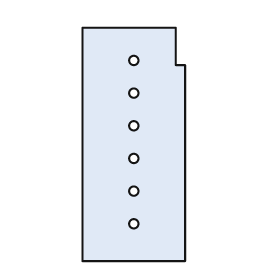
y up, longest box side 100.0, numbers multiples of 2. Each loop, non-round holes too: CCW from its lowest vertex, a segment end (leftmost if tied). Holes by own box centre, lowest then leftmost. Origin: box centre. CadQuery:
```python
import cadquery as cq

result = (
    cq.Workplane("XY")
    .moveTo(-22.0, -50.0)
    .lineTo(22.0, -50.0)
    .lineTo(22.0, 34.0)
    .lineTo(18.0, 34.0)
    .lineTo(18.0, 50.0)
    .lineTo(-22.0, 50.0)
    .close()
    .moveTo(0.0, -34.0)
    .circle(2.0)
    .moveTo(0.0, -20.0)
    .circle(2.0)
    .moveTo(0.0, -6.0)
    .circle(2.0)
    .moveTo(0.0, 8.0)
    .circle(2.0)
    .moveTo(0.0, 22.0)
    .circle(2.0)
    .moveTo(0.0, 36.0)
    .circle(2.0)
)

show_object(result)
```